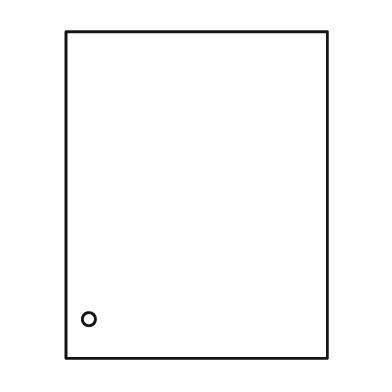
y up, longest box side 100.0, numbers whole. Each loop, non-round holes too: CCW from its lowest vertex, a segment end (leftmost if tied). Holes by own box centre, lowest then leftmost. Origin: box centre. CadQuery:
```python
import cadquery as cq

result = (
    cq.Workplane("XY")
    .moveTo(-40.0, -50.0)
    .lineTo(40.0, -50.0)
    .lineTo(40.0, 50.0)
    .lineTo(-40.0, 50.0)
    .close()
    .moveTo(-33.0, -38.0)
    .circle(2.0)
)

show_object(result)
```